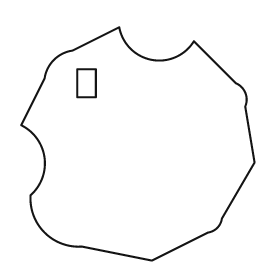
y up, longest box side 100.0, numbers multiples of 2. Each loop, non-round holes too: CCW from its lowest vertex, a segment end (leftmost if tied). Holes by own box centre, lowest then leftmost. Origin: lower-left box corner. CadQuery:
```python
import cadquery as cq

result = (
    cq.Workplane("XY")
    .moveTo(56.0, 0.0)
    .lineTo(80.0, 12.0)
    .threePointArc((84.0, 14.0), (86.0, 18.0))
    .lineTo(100.0, 42.0)
    .lineTo(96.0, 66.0)
    .threePointArc((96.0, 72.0), (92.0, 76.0))
    .lineTo(74.0, 94.0)
    .threePointArc((56.0, 86.0), (42.0, 100.0))
    .lineTo(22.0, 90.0)
    .threePointArc((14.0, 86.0), (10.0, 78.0))
    .lineTo(0.0, 58.0)
    .threePointArc((10.0, 44.0), (4.0, 28.0))
    .threePointArc((10.0, 12.0), (26.0, 6.0))
    .close()
    .moveTo(24.0, 70.0)
    .lineTo(32.0, 70.0)
    .lineTo(32.0, 82.0)
    .lineTo(24.0, 82.0)
    .close()
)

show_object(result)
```